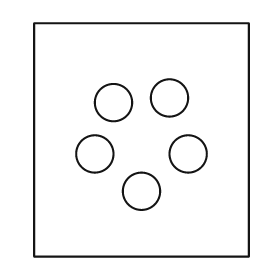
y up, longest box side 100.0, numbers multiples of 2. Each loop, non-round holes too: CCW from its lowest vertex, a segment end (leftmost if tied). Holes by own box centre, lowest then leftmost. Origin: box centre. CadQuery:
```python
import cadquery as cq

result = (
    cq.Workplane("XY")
    .moveTo(-46.0, -50.0)
    .lineTo(46.0, -50.0)
    .lineTo(46.0, 50.0)
    .lineTo(-46.0, 50.0)
    .close()
    .moveTo(0.0, -22.0)
    .circle(8.0)
    .moveTo(-20.0, -6.0)
    .circle(8.0)
    .moveTo(20.0, -6.0)
    .circle(8.0)
    .moveTo(-12.0, 16.0)
    .circle(8.0)
    .moveTo(12.0, 18.0)
    .circle(8.0)
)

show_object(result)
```